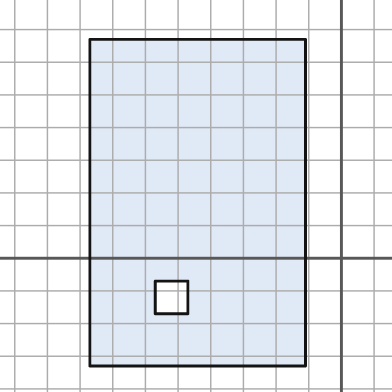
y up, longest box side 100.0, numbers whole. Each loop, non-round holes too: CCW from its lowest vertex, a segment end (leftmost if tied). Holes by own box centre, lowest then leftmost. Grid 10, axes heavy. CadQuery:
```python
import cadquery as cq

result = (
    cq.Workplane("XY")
    .moveTo(-77.0, -33.0)
    .lineTo(-11.0, -33.0)
    .lineTo(-11.0, 67.0)
    .lineTo(-77.0, 67.0)
    .close()
    .moveTo(-57.0, -17.0)
    .lineTo(-47.0, -17.0)
    .lineTo(-47.0, -7.0)
    .lineTo(-57.0, -7.0)
    .close()
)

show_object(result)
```